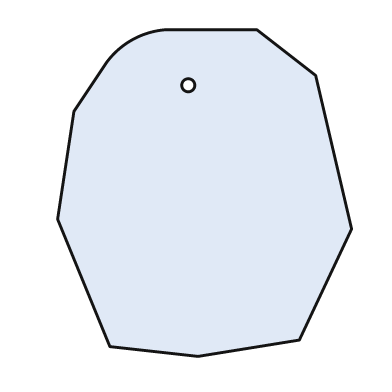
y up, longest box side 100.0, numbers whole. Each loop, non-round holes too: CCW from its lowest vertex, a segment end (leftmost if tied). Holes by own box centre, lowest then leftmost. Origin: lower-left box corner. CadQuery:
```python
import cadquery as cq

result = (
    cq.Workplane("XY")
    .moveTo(43.0, 0.0)
    .lineTo(74.0, 5.0)
    .lineTo(90.0, 39.0)
    .lineTo(79.0, 86.0)
    .lineTo(61.0, 100.0)
    .lineTo(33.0, 100.0)
    .threePointArc((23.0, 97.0), (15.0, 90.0))
    .lineTo(5.0, 75.0)
    .lineTo(0.0, 42.0)
    .lineTo(16.0, 3.0)
    .close()
    .moveTo(40.0, 83.0)
    .circle(2.0)
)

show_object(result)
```